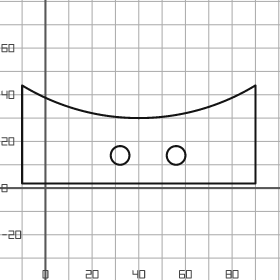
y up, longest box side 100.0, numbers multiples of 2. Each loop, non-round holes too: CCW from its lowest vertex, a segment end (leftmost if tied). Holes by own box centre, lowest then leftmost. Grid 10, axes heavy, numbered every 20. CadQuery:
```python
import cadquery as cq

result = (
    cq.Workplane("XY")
    .moveTo(-10.0, 2.0)
    .lineTo(90.0, 2.0)
    .lineTo(90.0, 44.0)
    .threePointArc((40.0, 30.0), (-10.0, 44.0))
    .close()
    .moveTo(32.0, 14.0)
    .circle(4.0)
    .moveTo(56.0, 14.0)
    .circle(4.0)
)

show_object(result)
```